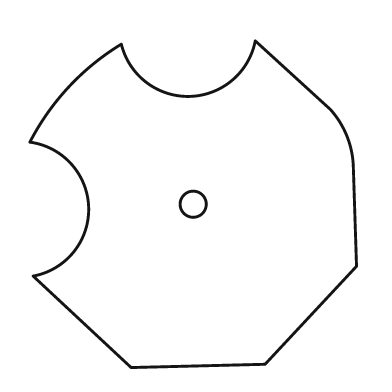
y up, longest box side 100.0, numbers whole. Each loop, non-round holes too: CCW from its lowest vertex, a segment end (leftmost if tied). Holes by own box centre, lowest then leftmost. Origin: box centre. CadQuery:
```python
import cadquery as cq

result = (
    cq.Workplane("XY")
    .moveTo(-19.0, -50.0)
    .lineTo(22.0, -49.0)
    .lineTo(50.0, -19.0)
    .lineTo(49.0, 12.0)
    .threePointArc((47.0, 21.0), (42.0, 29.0))
    .lineTo(19.0, 50.0)
    .threePointArc((-1.0, 33.0), (-22.0, 49.0))
    .threePointArc((-38.0, 36.0), (-50.0, 19.0))
    .threePointArc((-32.0, -1.0), (-49.0, -22.0))
    .close()
    .moveTo(0.0, 0.0)
    .circle(4.0)
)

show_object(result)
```